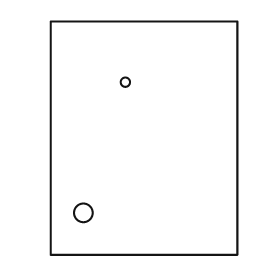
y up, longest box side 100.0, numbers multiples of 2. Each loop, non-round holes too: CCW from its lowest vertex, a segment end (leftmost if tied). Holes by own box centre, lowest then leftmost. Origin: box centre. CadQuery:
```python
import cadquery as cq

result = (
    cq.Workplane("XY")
    .moveTo(-40.0, -50.0)
    .lineTo(40.0, -50.0)
    .lineTo(40.0, 50.0)
    .lineTo(-40.0, 50.0)
    .close()
    .moveTo(-26.0, -32.0)
    .circle(4.0)
    .moveTo(-8.0, 24.0)
    .circle(2.0)
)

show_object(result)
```